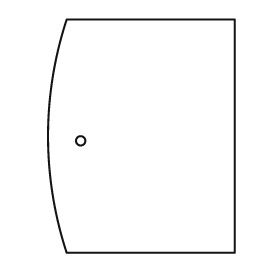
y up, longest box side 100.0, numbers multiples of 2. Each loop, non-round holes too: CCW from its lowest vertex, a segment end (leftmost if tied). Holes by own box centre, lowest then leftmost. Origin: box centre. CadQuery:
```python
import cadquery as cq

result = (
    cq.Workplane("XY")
    .moveTo(-32.0, -50.0)
    .lineTo(40.0, -50.0)
    .lineTo(40.0, 50.0)
    .lineTo(-32.0, 50.0)
    .threePointArc((-40.0, 0.0), (-32.0, -50.0))
    .close()
    .moveTo(-26.0, -2.0)
    .circle(2.0)
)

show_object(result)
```